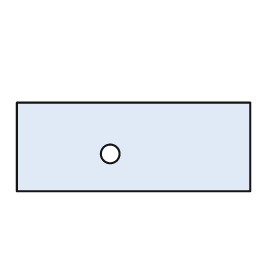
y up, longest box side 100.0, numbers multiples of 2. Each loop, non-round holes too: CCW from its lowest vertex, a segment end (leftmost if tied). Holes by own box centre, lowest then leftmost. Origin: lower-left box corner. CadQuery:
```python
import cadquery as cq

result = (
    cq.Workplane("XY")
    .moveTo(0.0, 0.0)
    .lineTo(100.0, 0.0)
    .lineTo(100.0, 38.0)
    .lineTo(0.0, 38.0)
    .close()
    .moveTo(40.0, 16.0)
    .circle(4.0)
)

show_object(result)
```